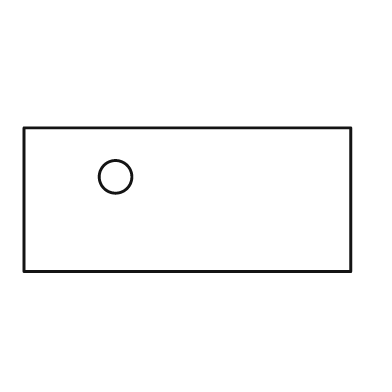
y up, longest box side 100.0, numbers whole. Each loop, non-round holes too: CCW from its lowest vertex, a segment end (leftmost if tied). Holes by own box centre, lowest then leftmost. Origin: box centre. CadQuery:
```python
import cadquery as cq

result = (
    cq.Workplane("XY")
    .moveTo(-50.0, -22.0)
    .lineTo(50.0, -22.0)
    .lineTo(50.0, 22.0)
    .lineTo(-50.0, 22.0)
    .close()
    .moveTo(-22.0, 7.0)
    .circle(5.0)
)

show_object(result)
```